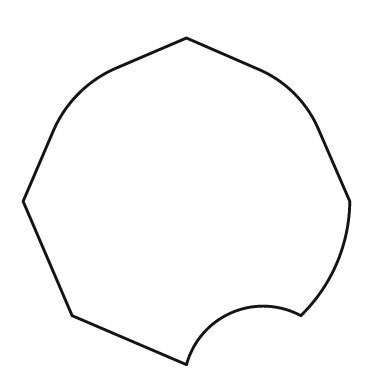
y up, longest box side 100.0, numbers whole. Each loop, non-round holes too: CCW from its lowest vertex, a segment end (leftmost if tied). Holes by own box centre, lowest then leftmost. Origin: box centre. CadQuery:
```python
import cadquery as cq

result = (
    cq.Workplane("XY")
    .moveTo(0.0, -50.0)
    .threePointArc((14.0, -34.0), (35.0, -35.0))
    .threePointArc((46.0, -19.0), (50.0, 0.0))
    .lineTo(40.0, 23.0)
    .threePointArc((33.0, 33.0), (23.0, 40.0))
    .lineTo(0.0, 50.0)
    .lineTo(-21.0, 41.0)
    .threePointArc((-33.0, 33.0), (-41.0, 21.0))
    .lineTo(-50.0, 0.0)
    .lineTo(-35.0, -35.0)
    .close()
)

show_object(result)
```